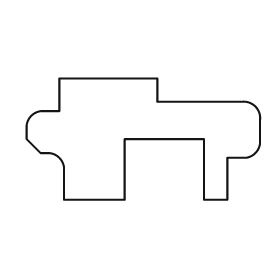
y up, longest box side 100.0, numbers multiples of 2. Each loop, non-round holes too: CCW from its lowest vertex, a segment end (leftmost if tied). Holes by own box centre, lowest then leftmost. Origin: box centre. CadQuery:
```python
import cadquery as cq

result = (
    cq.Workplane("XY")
    .moveTo(-34.0, -26.0)
    .lineTo(-8.0, -26.0)
    .lineTo(-8.0, 0.0)
    .lineTo(26.0, 0.0)
    .lineTo(26.0, -26.0)
    .lineTo(36.0, -26.0)
    .lineTo(36.0, -8.0)
    .lineTo(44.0, -8.0)
    .threePointArc((48.0, -6.0), (50.0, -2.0))
    .lineTo(50.0, 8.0)
    .threePointArc((48.0, 14.0), (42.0, 16.0))
    .lineTo(6.0, 16.0)
    .lineTo(6.0, 26.0)
    .lineTo(-36.0, 26.0)
    .lineTo(-36.0, 12.0)
    .lineTo(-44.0, 12.0)
    .threePointArc((-48.0, 10.0), (-50.0, 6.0))
    .lineTo(-50.0, 0.0)
    .lineTo(-44.0, -6.0)
    .lineTo(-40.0, -6.0)
    .threePointArc((-36.0, -8.0), (-34.0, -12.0))
    .close()
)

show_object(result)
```